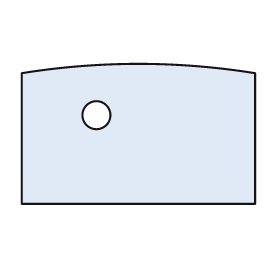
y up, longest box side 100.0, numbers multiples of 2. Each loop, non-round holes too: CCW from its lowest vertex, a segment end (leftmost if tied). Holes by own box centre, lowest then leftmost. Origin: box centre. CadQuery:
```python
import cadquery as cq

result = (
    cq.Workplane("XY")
    .moveTo(-50.0, -30.0)
    .lineTo(50.0, -30.0)
    .lineTo(50.0, 26.0)
    .threePointArc((0.0, 30.0), (-50.0, 26.0))
    .close()
    .moveTo(-18.0, 8.0)
    .circle(6.0)
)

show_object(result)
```